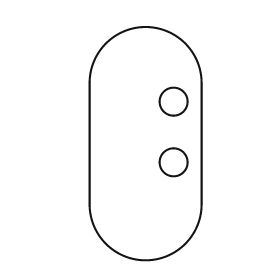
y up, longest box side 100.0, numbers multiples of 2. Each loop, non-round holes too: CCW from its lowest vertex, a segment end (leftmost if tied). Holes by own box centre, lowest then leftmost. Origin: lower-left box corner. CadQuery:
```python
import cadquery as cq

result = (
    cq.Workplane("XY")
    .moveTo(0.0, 24.0)
    .threePointArc((24.0, 0.0), (48.0, 24.0))
    .lineTo(48.0, 76.0)
    .threePointArc((24.0, 100.0), (0.0, 76.0))
    .close()
    .moveTo(36.0, 42.0)
    .circle(6.0)
    .moveTo(36.0, 68.0)
    .circle(6.0)
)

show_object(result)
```